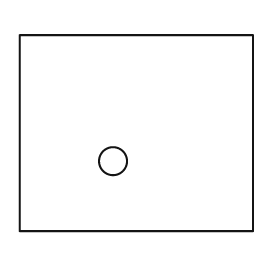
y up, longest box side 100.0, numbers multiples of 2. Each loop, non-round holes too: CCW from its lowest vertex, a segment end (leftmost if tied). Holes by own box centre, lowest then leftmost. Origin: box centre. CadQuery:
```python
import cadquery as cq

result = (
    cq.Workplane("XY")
    .moveTo(-50.0, -42.0)
    .lineTo(50.0, -42.0)
    .lineTo(50.0, 42.0)
    .lineTo(-50.0, 42.0)
    .close()
    .moveTo(-10.0, -12.0)
    .circle(6.0)
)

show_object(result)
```